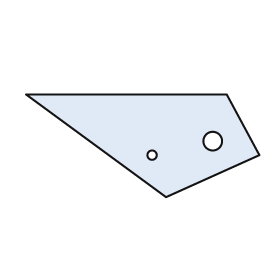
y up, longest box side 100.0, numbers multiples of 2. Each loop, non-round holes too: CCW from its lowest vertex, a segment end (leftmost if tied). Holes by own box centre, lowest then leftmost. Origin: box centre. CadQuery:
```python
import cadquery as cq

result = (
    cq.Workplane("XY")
    .moveTo(10.0, -22.0)
    .lineTo(50.0, -4.0)
    .lineTo(36.0, 22.0)
    .lineTo(-50.0, 22.0)
    .close()
    .moveTo(4.0, -4.0)
    .circle(2.0)
    .moveTo(30.0, 2.0)
    .circle(4.0)
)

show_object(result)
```